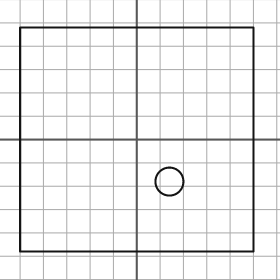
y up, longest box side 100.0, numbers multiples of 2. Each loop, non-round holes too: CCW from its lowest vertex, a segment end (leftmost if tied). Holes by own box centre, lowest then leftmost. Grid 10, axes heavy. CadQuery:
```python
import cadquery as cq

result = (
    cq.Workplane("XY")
    .moveTo(-50.0, -48.0)
    .lineTo(50.0, -48.0)
    .lineTo(50.0, 48.0)
    .lineTo(-50.0, 48.0)
    .close()
    .moveTo(14.0, -18.0)
    .circle(6.0)
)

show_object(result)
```